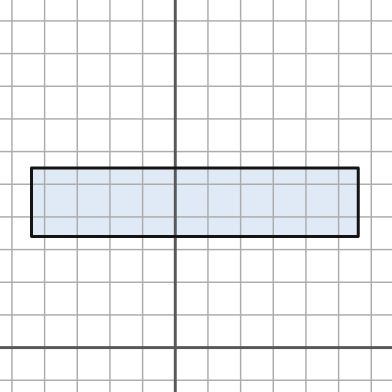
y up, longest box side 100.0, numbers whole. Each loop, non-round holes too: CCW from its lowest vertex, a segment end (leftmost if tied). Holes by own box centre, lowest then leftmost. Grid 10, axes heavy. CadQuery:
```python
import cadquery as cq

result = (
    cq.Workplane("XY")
    .moveTo(-44.0, 34.0)
    .lineTo(56.0, 34.0)
    .lineTo(56.0, 55.0)
    .lineTo(-44.0, 55.0)
    .close()
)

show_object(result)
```